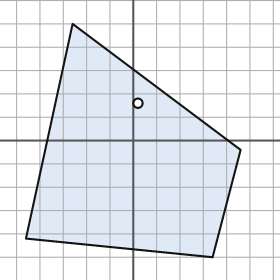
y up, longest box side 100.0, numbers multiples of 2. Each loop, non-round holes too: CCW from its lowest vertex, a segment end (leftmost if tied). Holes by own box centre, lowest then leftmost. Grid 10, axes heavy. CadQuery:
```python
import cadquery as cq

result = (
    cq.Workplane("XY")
    .moveTo(34.0, -50.0)
    .lineTo(46.0, -4.0)
    .lineTo(-26.0, 50.0)
    .lineTo(-46.0, -42.0)
    .close()
    .moveTo(2.0, 16.0)
    .circle(2.0)
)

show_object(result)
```